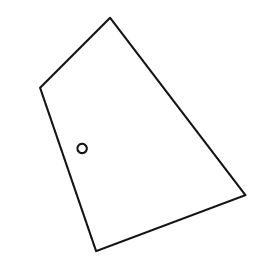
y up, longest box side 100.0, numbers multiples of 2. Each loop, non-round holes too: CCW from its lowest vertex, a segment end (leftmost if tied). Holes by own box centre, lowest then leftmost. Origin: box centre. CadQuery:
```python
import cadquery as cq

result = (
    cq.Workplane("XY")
    .moveTo(-20.0, -50.0)
    .lineTo(44.0, -26.0)
    .lineTo(-14.0, 50.0)
    .lineTo(-44.0, 20.0)
    .close()
    .moveTo(-26.0, -6.0)
    .circle(2.0)
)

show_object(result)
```